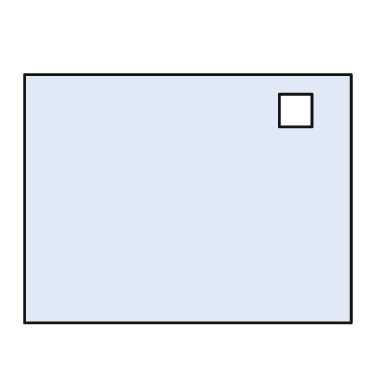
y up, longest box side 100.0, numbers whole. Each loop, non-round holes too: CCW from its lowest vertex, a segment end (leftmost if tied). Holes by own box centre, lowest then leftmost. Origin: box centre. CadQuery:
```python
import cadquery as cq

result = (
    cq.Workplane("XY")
    .moveTo(-50.0, -38.0)
    .lineTo(50.0, -38.0)
    .lineTo(50.0, 38.0)
    .lineTo(-50.0, 38.0)
    .close()
    .moveTo(28.0, 22.0)
    .lineTo(38.0, 22.0)
    .lineTo(38.0, 32.0)
    .lineTo(28.0, 32.0)
    .close()
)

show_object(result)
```